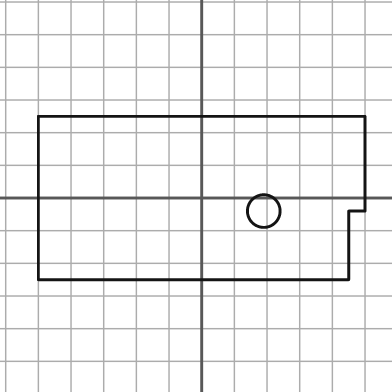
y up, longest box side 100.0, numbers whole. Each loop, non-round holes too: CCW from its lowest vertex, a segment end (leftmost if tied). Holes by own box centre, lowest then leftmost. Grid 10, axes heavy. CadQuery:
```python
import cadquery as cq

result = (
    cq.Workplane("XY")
    .moveTo(-50.0, -25.0)
    .lineTo(45.0, -25.0)
    .lineTo(45.0, -4.0)
    .lineTo(50.0, -4.0)
    .lineTo(50.0, 25.0)
    .lineTo(-50.0, 25.0)
    .close()
    .moveTo(19.0, -4.0)
    .circle(5.0)
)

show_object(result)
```